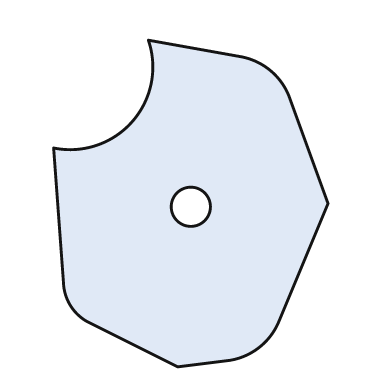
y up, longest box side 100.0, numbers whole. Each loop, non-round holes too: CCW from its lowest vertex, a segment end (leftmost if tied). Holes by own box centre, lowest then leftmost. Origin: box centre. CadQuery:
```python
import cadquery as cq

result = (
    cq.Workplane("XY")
    .moveTo(-4.0, -50.0)
    .lineTo(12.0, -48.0)
    .threePointArc((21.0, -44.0), (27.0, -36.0))
    .lineTo(42.0, 0.0)
    .lineTo(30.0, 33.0)
    .threePointArc((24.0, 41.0), (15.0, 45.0))
    .lineTo(-13.0, 50.0)
    .threePointArc((-18.0, 25.0), (-42.0, 17.0))
    .lineTo(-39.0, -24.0)
    .threePointArc((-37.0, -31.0), (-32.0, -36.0))
    .close()
    .moveTo(0.0, -1.0)
    .circle(6.0)
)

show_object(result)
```